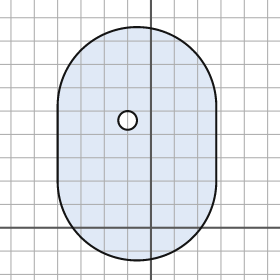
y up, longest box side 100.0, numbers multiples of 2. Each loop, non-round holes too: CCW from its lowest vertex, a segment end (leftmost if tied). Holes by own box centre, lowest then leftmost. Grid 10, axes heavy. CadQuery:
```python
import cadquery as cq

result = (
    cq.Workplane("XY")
    .moveTo(-40.0, 20.0)
    .threePointArc((-6.0, -14.0), (28.0, 20.0))
    .lineTo(28.0, 52.0)
    .threePointArc((-6.0, 86.0), (-40.0, 52.0))
    .close()
    .moveTo(-10.0, 46.0)
    .circle(4.0)
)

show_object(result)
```